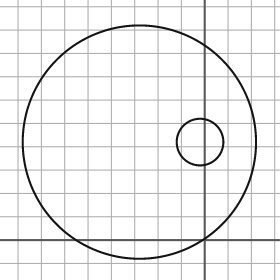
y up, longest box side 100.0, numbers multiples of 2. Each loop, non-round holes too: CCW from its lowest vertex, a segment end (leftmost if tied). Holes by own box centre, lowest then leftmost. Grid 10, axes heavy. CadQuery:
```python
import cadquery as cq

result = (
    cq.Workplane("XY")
    .moveTo(-28.0, 42.0)
    .circle(50.0)
    .moveTo(-2.0, 42.0)
    .circle(10.0)
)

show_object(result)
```